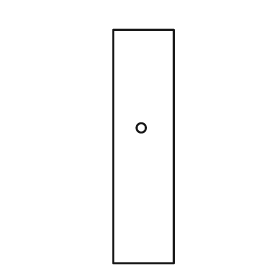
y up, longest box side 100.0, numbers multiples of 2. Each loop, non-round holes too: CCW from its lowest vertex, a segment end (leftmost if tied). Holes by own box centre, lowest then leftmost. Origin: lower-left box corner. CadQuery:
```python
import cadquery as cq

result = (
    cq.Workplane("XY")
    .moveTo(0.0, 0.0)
    .lineTo(26.0, 0.0)
    .lineTo(26.0, 100.0)
    .lineTo(0.0, 100.0)
    .close()
    .moveTo(12.0, 58.0)
    .circle(2.0)
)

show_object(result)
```